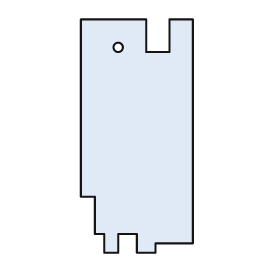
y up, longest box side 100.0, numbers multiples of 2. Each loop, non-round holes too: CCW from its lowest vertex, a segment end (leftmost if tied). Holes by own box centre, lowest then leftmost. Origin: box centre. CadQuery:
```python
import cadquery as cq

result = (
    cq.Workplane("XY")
    .moveTo(-14.0, -50.0)
    .lineTo(-8.0, -50.0)
    .lineTo(-8.0, -42.0)
    .lineTo(0.0, -42.0)
    .lineTo(0.0, -50.0)
    .lineTo(8.0, -50.0)
    .lineTo(8.0, -46.0)
    .lineTo(24.0, -46.0)
    .lineTo(24.0, 50.0)
    .lineTo(14.0, 50.0)
    .lineTo(14.0, 36.0)
    .lineTo(4.0, 36.0)
    .lineTo(4.0, 50.0)
    .lineTo(-24.0, 50.0)
    .lineTo(-24.0, -26.0)
    .lineTo(-18.0, -26.0)
    .lineTo(-18.0, -42.0)
    .lineTo(-14.0, -42.0)
    .close()
    .moveTo(-8.0, 38.0)
    .circle(2.0)
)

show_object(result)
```